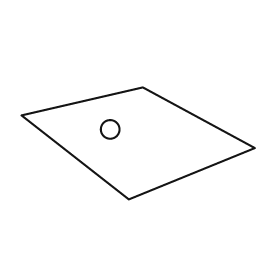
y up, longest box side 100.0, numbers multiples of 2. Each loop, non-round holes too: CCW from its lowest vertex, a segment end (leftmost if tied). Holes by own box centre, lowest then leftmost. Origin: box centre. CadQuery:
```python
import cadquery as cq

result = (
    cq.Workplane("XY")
    .moveTo(-4.0, -24.0)
    .lineTo(50.0, -2.0)
    .lineTo(2.0, 24.0)
    .lineTo(-50.0, 12.0)
    .close()
    .moveTo(-12.0, 6.0)
    .circle(4.0)
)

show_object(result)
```